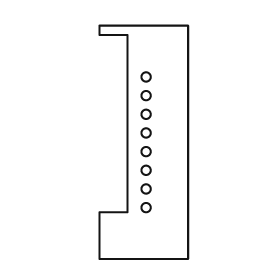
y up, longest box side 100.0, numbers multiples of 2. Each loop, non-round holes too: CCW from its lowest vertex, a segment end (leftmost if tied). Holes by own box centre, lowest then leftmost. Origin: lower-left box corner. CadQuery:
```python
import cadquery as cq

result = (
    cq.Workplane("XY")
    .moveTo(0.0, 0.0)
    .lineTo(38.0, 0.0)
    .lineTo(38.0, 100.0)
    .lineTo(0.0, 100.0)
    .lineTo(0.0, 96.0)
    .lineTo(12.0, 96.0)
    .lineTo(12.0, 20.0)
    .lineTo(0.0, 20.0)
    .close()
    .moveTo(20.0, 22.0)
    .circle(2.0)
    .moveTo(20.0, 30.0)
    .circle(2.0)
    .moveTo(20.0, 38.0)
    .circle(2.0)
    .moveTo(20.0, 46.0)
    .circle(2.0)
    .moveTo(20.0, 54.0)
    .circle(2.0)
    .moveTo(20.0, 62.0)
    .circle(2.0)
    .moveTo(20.0, 70.0)
    .circle(2.0)
    .moveTo(20.0, 78.0)
    .circle(2.0)
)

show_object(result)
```